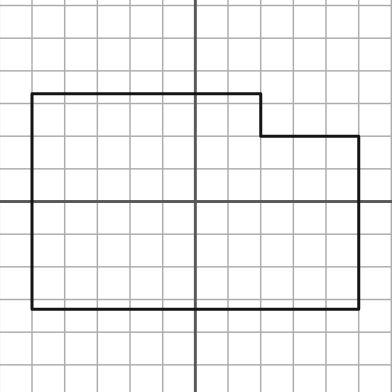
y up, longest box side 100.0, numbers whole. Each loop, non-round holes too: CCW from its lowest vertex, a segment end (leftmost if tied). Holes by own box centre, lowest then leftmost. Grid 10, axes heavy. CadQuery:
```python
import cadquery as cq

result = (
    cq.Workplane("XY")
    .moveTo(-50.0, -33.0)
    .lineTo(50.0, -33.0)
    .lineTo(50.0, 20.0)
    .lineTo(20.0, 20.0)
    .lineTo(20.0, 33.0)
    .lineTo(-50.0, 33.0)
    .close()
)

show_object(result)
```